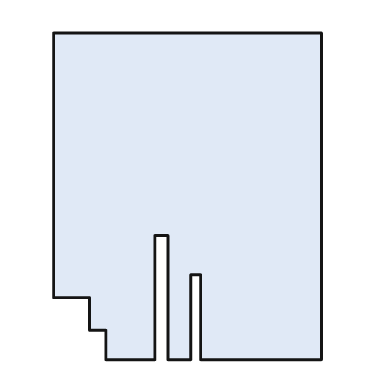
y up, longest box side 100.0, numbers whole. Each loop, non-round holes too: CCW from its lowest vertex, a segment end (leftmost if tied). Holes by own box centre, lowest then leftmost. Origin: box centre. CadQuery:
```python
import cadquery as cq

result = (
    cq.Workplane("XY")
    .moveTo(-25.0, -50.0)
    .lineTo(-10.0, -50.0)
    .lineTo(-10.0, -12.0)
    .lineTo(-6.0, -12.0)
    .lineTo(-6.0, -50.0)
    .lineTo(1.0, -50.0)
    .lineTo(1.0, -24.0)
    .lineTo(4.0, -24.0)
    .lineTo(4.0, -50.0)
    .lineTo(41.0, -50.0)
    .lineTo(41.0, 50.0)
    .lineTo(-41.0, 50.0)
    .lineTo(-41.0, -31.0)
    .lineTo(-30.0, -31.0)
    .lineTo(-30.0, -41.0)
    .lineTo(-25.0, -41.0)
    .close()
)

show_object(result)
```